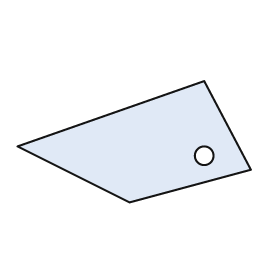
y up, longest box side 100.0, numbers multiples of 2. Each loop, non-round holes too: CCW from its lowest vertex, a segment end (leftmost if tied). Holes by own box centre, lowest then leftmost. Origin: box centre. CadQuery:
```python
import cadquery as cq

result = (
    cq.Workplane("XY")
    .moveTo(-2.0, -26.0)
    .lineTo(50.0, -12.0)
    .lineTo(30.0, 26.0)
    .lineTo(-50.0, -2.0)
    .close()
    .moveTo(30.0, -6.0)
    .circle(4.0)
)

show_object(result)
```